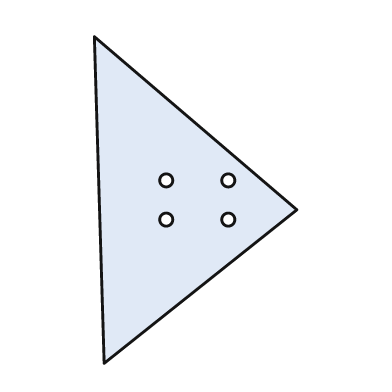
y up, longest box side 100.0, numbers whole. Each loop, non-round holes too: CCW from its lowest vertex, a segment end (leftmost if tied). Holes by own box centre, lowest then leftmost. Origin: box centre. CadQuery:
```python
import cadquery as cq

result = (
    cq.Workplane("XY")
    .moveTo(-28.0, -50.0)
    .lineTo(31.0, -3.0)
    .lineTo(-31.0, 50.0)
    .close()
    .moveTo(-9.0, -6.0)
    .circle(2.0)
    .moveTo(10.0, -6.0)
    .circle(2.0)
    .moveTo(-9.0, 6.0)
    .circle(2.0)
    .moveTo(10.0, 6.0)
    .circle(2.0)
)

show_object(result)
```